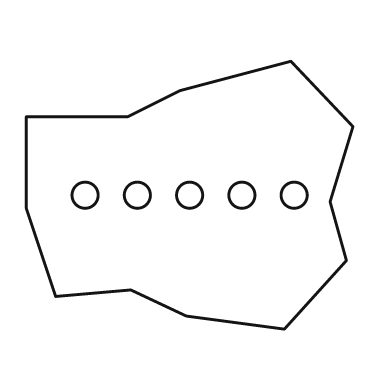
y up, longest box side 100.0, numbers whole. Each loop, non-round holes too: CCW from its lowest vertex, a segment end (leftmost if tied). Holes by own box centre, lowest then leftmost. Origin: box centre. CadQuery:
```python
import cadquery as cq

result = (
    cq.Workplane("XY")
    .moveTo(29.0, -41.0)
    .lineTo(48.0, -20.0)
    .lineTo(43.0, -2.0)
    .lineTo(50.0, 21.0)
    .lineTo(31.0, 41.0)
    .lineTo(-3.0, 32.0)
    .lineTo(-19.0, 24.0)
    .lineTo(-50.0, 24.0)
    .lineTo(-50.0, -4.0)
    .lineTo(-41.0, -31.0)
    .lineTo(-18.0, -29.0)
    .lineTo(-1.0, -37.0)
    .close()
    .moveTo(-32.0, 0.0)
    .circle(4.0)
    .moveTo(-16.0, 0.0)
    .circle(4.0)
    .moveTo(0.0, 0.0)
    .circle(4.0)
    .moveTo(16.0, 0.0)
    .circle(4.0)
    .moveTo(32.0, 0.0)
    .circle(4.0)
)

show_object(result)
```